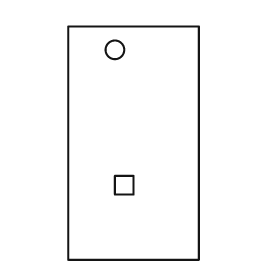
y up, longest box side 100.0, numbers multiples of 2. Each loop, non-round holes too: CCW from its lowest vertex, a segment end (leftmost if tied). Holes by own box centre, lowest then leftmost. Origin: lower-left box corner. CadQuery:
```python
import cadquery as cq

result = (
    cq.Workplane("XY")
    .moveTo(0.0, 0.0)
    .lineTo(56.0, 0.0)
    .lineTo(56.0, 100.0)
    .lineTo(0.0, 100.0)
    .close()
    .moveTo(20.0, 28.0)
    .lineTo(28.0, 28.0)
    .lineTo(28.0, 36.0)
    .lineTo(20.0, 36.0)
    .close()
    .moveTo(20.0, 90.0)
    .circle(4.0)
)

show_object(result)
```